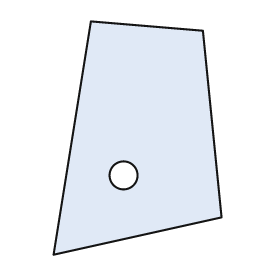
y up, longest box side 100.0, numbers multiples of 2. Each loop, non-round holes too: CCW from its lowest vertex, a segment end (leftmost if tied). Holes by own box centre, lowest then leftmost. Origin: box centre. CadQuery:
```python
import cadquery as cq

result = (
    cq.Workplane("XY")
    .moveTo(-36.0, -50.0)
    .lineTo(36.0, -34.0)
    .lineTo(28.0, 46.0)
    .lineTo(-20.0, 50.0)
    .close()
    .moveTo(-6.0, -16.0)
    .circle(6.0)
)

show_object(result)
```